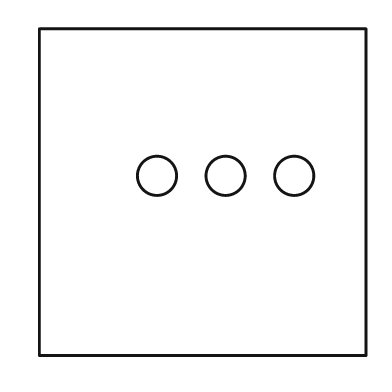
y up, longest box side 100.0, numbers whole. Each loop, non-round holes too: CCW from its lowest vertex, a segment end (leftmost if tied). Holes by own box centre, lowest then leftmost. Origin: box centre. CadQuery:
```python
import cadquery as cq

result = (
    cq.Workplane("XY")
    .moveTo(-50.0, -50.0)
    .lineTo(50.0, -50.0)
    .lineTo(50.0, 50.0)
    .lineTo(-50.0, 50.0)
    .close()
    .moveTo(-14.0, 5.0)
    .circle(6.0)
    .moveTo(7.0, 5.0)
    .circle(6.0)
    .moveTo(28.0, 5.0)
    .circle(6.0)
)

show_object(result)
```